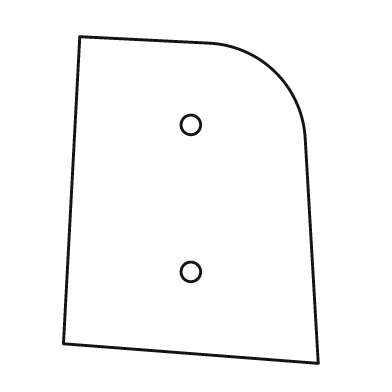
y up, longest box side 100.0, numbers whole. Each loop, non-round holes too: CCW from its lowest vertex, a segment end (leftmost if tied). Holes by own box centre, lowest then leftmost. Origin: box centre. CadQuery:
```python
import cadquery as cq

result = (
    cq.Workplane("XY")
    .moveTo(39.0, -50.0)
    .lineTo(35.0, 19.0)
    .threePointArc((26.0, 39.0), (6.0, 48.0))
    .lineTo(-34.0, 50.0)
    .lineTo(-39.0, -44.0)
    .close()
    .moveTo(0.0, -22.0)
    .circle(3.0)
    .moveTo(0.0, 23.0)
    .circle(3.0)
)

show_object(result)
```